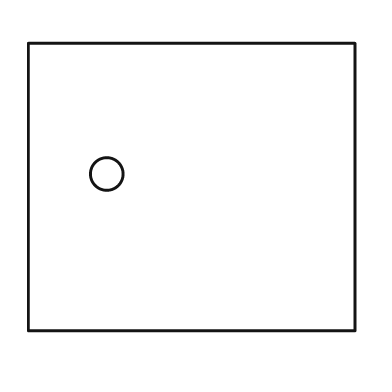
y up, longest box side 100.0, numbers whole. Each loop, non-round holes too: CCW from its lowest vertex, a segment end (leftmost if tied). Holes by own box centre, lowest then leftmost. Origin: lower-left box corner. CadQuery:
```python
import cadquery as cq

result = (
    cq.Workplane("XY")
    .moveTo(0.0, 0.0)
    .lineTo(100.0, 0.0)
    .lineTo(100.0, 88.0)
    .lineTo(0.0, 88.0)
    .close()
    .moveTo(24.0, 48.0)
    .circle(5.0)
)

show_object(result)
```